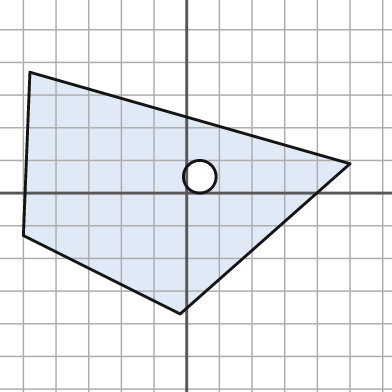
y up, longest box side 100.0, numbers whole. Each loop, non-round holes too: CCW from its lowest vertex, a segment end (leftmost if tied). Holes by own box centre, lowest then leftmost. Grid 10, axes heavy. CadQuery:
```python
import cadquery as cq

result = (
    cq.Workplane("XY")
    .moveTo(-2.0, -37.0)
    .lineTo(50.0, 9.0)
    .lineTo(-48.0, 37.0)
    .lineTo(-50.0, -13.0)
    .close()
    .moveTo(4.0, 5.0)
    .circle(5.0)
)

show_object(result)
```